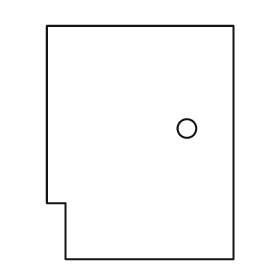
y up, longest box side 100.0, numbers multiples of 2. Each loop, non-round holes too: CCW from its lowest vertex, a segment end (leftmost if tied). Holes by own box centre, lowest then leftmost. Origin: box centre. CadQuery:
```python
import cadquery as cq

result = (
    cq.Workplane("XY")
    .moveTo(-32.0, -50.0)
    .lineTo(40.0, -50.0)
    .lineTo(40.0, 50.0)
    .lineTo(-40.0, 50.0)
    .lineTo(-40.0, -26.0)
    .lineTo(-32.0, -26.0)
    .close()
    .moveTo(20.0, 6.0)
    .circle(4.0)
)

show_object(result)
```